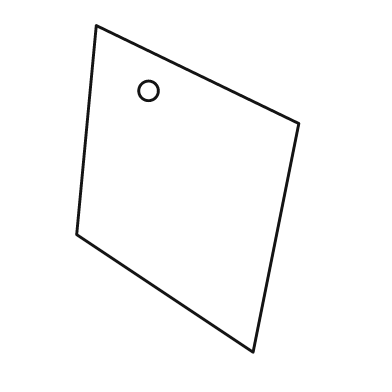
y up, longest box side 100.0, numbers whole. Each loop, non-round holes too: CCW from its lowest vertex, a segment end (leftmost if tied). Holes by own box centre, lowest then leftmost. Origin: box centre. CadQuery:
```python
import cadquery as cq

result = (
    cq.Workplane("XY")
    .moveTo(20.0, -50.0)
    .lineTo(34.0, 20.0)
    .lineTo(-28.0, 50.0)
    .lineTo(-34.0, -14.0)
    .close()
    .moveTo(-12.0, 30.0)
    .circle(3.0)
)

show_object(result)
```